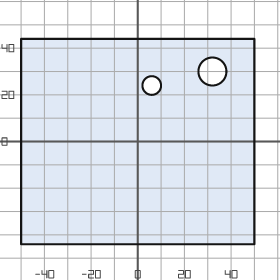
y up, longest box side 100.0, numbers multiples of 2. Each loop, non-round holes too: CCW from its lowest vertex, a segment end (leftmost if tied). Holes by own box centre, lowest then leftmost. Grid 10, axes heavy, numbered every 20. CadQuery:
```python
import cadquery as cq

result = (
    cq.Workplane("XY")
    .moveTo(-50.0, -44.0)
    .lineTo(50.0, -44.0)
    .lineTo(50.0, 44.0)
    .lineTo(-50.0, 44.0)
    .close()
    .moveTo(6.0, 24.0)
    .circle(4.0)
    .moveTo(32.0, 30.0)
    .circle(6.0)
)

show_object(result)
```